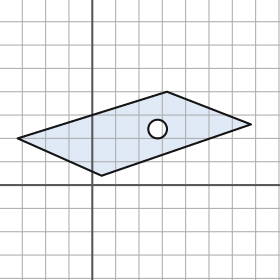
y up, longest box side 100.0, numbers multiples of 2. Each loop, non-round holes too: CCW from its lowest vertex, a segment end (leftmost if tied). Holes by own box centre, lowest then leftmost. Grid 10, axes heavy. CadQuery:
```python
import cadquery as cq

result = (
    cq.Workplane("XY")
    .moveTo(4.0, 4.0)
    .lineTo(68.0, 26.0)
    .lineTo(32.0, 40.0)
    .lineTo(-32.0, 20.0)
    .close()
    .moveTo(28.0, 24.0)
    .circle(4.0)
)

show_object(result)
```